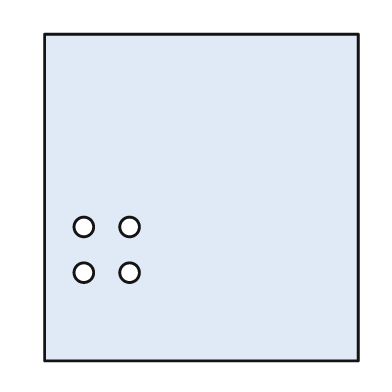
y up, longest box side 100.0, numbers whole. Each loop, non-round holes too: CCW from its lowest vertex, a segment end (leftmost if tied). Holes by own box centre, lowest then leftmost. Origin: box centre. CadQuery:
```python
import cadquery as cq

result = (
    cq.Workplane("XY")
    .moveTo(-48.0, -50.0)
    .lineTo(48.0, -50.0)
    .lineTo(48.0, 50.0)
    .lineTo(-48.0, 50.0)
    .close()
    .moveTo(-36.0, -23.0)
    .circle(3.0)
    .moveTo(-22.0, -23.0)
    .circle(3.0)
    .moveTo(-36.0, -9.0)
    .circle(3.0)
    .moveTo(-22.0, -9.0)
    .circle(3.0)
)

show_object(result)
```